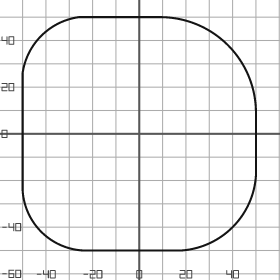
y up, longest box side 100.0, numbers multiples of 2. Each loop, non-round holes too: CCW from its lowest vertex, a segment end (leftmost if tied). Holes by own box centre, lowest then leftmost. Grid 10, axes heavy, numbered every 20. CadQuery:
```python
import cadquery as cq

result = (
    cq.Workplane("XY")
    .moveTo(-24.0, -50.0)
    .lineTo(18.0, -50.0)
    .threePointArc((40.0, -40.0), (50.0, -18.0))
    .lineTo(50.0, 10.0)
    .threePointArc((38.0, 38.0), (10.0, 50.0))
    .lineTo(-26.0, 50.0)
    .threePointArc((-42.0, 42.0), (-50.0, 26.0))
    .lineTo(-50.0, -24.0)
    .threePointArc((-42.0, -42.0), (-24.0, -50.0))
    .close()
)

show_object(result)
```